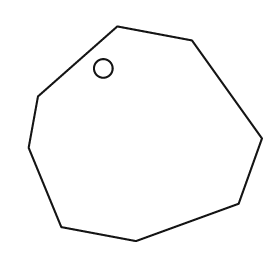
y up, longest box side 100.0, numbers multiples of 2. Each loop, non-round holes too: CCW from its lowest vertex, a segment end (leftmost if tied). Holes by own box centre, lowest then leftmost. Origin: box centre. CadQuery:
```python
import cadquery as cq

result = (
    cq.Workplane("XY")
    .moveTo(-4.0, -46.0)
    .lineTo(40.0, -30.0)
    .lineTo(50.0, -2.0)
    .lineTo(20.0, 40.0)
    .lineTo(-12.0, 46.0)
    .lineTo(-46.0, 16.0)
    .lineTo(-50.0, -6.0)
    .lineTo(-36.0, -40.0)
    .close()
    .moveTo(-18.0, 28.0)
    .circle(4.0)
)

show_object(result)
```